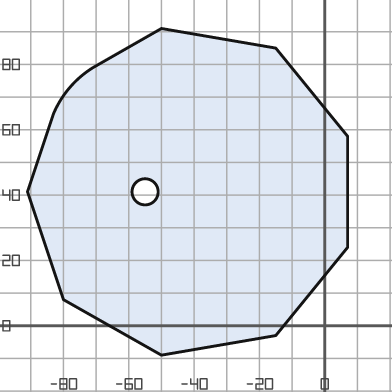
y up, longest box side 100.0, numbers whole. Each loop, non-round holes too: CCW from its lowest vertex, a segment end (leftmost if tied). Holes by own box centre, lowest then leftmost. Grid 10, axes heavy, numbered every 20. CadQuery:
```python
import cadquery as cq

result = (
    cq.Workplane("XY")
    .moveTo(-50.0, -9.0)
    .lineTo(-15.0, -3.0)
    .lineTo(7.0, 24.0)
    .lineTo(7.0, 58.0)
    .lineTo(-15.0, 85.0)
    .lineTo(-50.0, 91.0)
    .lineTo(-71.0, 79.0)
    .threePointArc((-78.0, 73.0), (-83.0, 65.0))
    .lineTo(-91.0, 41.0)
    .lineTo(-80.0, 8.0)
    .close()
    .moveTo(-55.0, 41.0)
    .circle(4.0)
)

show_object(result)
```